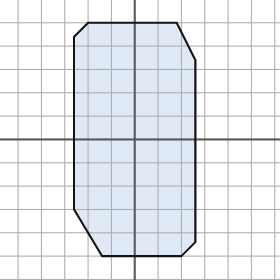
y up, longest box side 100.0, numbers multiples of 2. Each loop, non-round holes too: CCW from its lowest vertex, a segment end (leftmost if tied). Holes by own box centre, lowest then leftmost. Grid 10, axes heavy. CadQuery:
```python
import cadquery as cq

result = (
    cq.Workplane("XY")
    .moveTo(-14.0, -50.0)
    .lineTo(20.0, -50.0)
    .lineTo(26.0, -44.0)
    .lineTo(26.0, 34.0)
    .lineTo(18.0, 50.0)
    .lineTo(-20.0, 50.0)
    .lineTo(-26.0, 44.0)
    .lineTo(-26.0, -30.0)
    .close()
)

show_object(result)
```